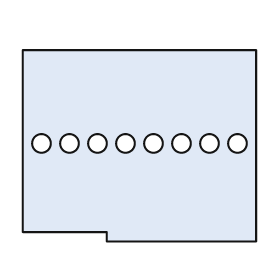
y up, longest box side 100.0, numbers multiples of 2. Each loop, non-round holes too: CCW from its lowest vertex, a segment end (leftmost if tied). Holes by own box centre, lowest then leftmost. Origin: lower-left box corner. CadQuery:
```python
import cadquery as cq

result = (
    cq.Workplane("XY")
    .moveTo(36.0, 0.0)
    .lineTo(100.0, 0.0)
    .lineTo(100.0, 82.0)
    .lineTo(0.0, 82.0)
    .lineTo(0.0, 4.0)
    .lineTo(36.0, 4.0)
    .close()
    .moveTo(8.0, 42.0)
    .circle(4.0)
    .moveTo(20.0, 42.0)
    .circle(4.0)
    .moveTo(32.0, 42.0)
    .circle(4.0)
    .moveTo(44.0, 42.0)
    .circle(4.0)
    .moveTo(56.0, 42.0)
    .circle(4.0)
    .moveTo(68.0, 42.0)
    .circle(4.0)
    .moveTo(80.0, 42.0)
    .circle(4.0)
    .moveTo(92.0, 42.0)
    .circle(4.0)
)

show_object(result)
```